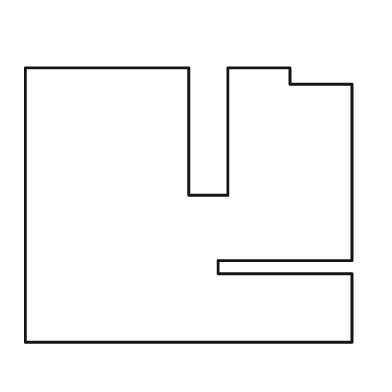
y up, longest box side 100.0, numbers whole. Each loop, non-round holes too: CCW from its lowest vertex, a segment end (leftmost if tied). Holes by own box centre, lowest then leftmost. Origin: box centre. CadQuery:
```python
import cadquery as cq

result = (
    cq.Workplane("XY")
    .moveTo(-50.0, -42.0)
    .lineTo(50.0, -42.0)
    .lineTo(50.0, -21.0)
    .lineTo(9.0, -21.0)
    .lineTo(9.0, -17.0)
    .lineTo(50.0, -17.0)
    .lineTo(50.0, 37.0)
    .lineTo(31.0, 37.0)
    .lineTo(31.0, 42.0)
    .lineTo(12.0, 42.0)
    .lineTo(12.0, 3.0)
    .lineTo(0.0, 3.0)
    .lineTo(0.0, 42.0)
    .lineTo(-50.0, 42.0)
    .close()
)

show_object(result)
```